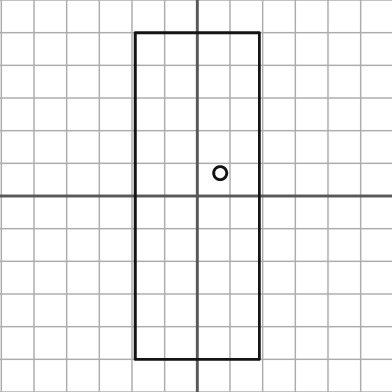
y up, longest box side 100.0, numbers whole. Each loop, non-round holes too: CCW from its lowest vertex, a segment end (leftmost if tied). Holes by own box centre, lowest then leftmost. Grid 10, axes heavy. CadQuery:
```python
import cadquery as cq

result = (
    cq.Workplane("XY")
    .moveTo(-19.0, -50.0)
    .lineTo(19.0, -50.0)
    .lineTo(19.0, 50.0)
    .lineTo(-19.0, 50.0)
    .close()
    .moveTo(7.0, 7.0)
    .circle(2.0)
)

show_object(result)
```